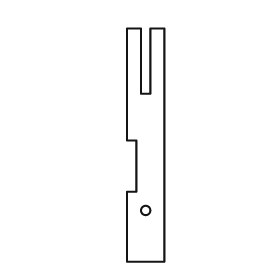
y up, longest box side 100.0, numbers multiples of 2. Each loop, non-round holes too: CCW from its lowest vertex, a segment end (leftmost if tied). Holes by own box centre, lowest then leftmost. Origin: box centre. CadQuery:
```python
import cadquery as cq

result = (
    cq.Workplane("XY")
    .moveTo(-8.0, -50.0)
    .lineTo(8.0, -50.0)
    .lineTo(8.0, 50.0)
    .lineTo(2.0, 50.0)
    .lineTo(2.0, 22.0)
    .lineTo(-2.0, 22.0)
    .lineTo(-2.0, 50.0)
    .lineTo(-8.0, 50.0)
    .lineTo(-8.0, 2.0)
    .lineTo(-4.0, 2.0)
    .lineTo(-4.0, -20.0)
    .lineTo(-8.0, -20.0)
    .close()
    .moveTo(0.0, -28.0)
    .circle(2.0)
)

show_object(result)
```